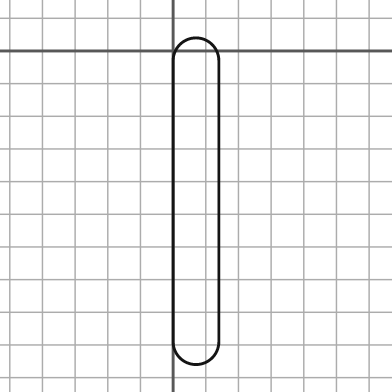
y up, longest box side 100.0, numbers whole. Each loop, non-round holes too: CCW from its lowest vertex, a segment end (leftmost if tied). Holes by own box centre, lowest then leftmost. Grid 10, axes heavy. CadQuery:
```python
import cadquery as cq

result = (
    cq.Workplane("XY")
    .moveTo(0.0, -89.0)
    .threePointArc((7.0, -96.0), (14.0, -89.0))
    .lineTo(14.0, -3.0)
    .threePointArc((7.0, 4.0), (0.0, -3.0))
    .close()
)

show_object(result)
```